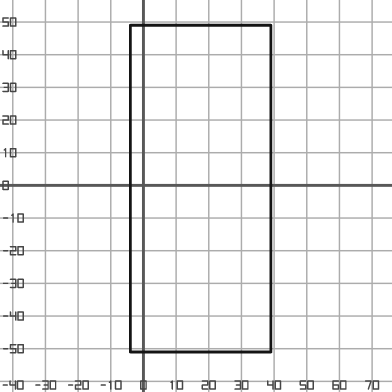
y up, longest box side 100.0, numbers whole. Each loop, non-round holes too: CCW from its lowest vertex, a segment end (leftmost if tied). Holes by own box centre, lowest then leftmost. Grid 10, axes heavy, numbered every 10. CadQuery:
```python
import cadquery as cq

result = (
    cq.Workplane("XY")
    .moveTo(-4.0, -51.0)
    .lineTo(39.0, -51.0)
    .lineTo(39.0, 49.0)
    .lineTo(-4.0, 49.0)
    .close()
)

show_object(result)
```